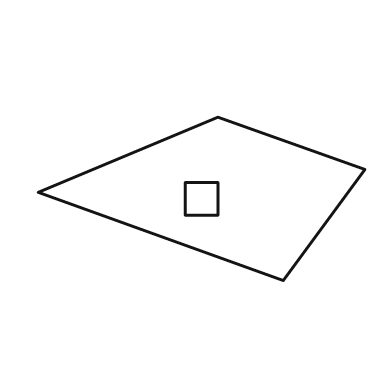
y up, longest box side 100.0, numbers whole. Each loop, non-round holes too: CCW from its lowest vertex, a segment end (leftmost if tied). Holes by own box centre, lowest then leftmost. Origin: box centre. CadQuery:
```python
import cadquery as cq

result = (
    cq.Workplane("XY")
    .moveTo(25.0, -25.0)
    .lineTo(50.0, 9.0)
    .lineTo(5.0, 25.0)
    .lineTo(-50.0, 2.0)
    .close()
    .moveTo(-5.0, -5.0)
    .lineTo(5.0, -5.0)
    .lineTo(5.0, 5.0)
    .lineTo(-5.0, 5.0)
    .close()
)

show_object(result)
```